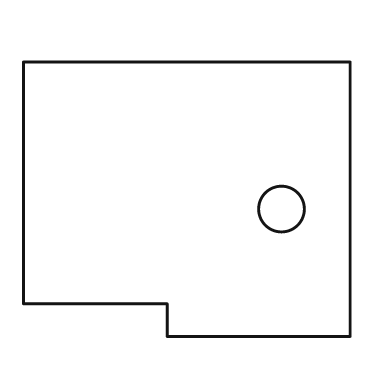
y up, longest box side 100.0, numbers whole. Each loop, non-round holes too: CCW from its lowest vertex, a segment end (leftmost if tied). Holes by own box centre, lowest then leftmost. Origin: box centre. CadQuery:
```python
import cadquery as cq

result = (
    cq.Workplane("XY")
    .moveTo(-6.0, -42.0)
    .lineTo(50.0, -42.0)
    .lineTo(50.0, 42.0)
    .lineTo(-50.0, 42.0)
    .lineTo(-50.0, -32.0)
    .lineTo(-6.0, -32.0)
    .close()
    .moveTo(29.0, -3.0)
    .circle(7.0)
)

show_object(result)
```